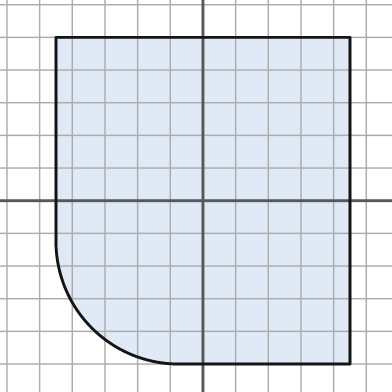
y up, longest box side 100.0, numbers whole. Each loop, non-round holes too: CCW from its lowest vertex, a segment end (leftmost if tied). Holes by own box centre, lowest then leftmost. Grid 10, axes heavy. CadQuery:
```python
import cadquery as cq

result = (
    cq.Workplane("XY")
    .moveTo(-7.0, -50.0)
    .lineTo(45.0, -50.0)
    .lineTo(45.0, 50.0)
    .lineTo(-45.0, 50.0)
    .lineTo(-45.0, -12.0)
    .threePointArc((-34.0, -39.0), (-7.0, -50.0))
    .close()
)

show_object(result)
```